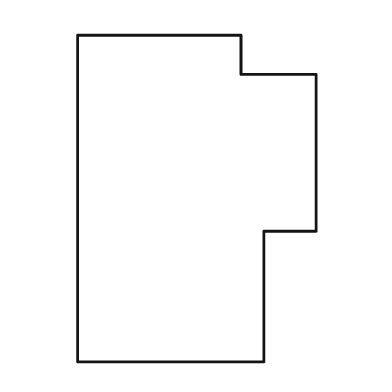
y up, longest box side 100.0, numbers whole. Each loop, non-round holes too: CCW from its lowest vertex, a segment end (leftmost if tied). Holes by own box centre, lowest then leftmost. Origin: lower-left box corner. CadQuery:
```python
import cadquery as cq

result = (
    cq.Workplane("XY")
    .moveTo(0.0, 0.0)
    .lineTo(57.0, 0.0)
    .lineTo(57.0, 40.0)
    .lineTo(73.0, 40.0)
    .lineTo(73.0, 88.0)
    .lineTo(50.0, 88.0)
    .lineTo(50.0, 100.0)
    .lineTo(0.0, 100.0)
    .close()
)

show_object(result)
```